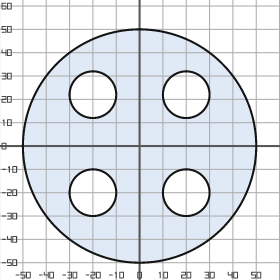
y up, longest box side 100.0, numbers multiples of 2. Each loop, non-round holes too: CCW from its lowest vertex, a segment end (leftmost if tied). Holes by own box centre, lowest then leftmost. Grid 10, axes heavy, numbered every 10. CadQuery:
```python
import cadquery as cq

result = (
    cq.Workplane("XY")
    .moveTo(0.0, 0.0)
    .circle(50.0)
    .moveTo(-20.0, -20.0)
    .circle(10.0)
    .moveTo(20.0, -20.0)
    .circle(10.0)
    .moveTo(-20.0, 22.0)
    .circle(10.0)
    .moveTo(20.0, 22.0)
    .circle(10.0)
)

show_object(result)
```